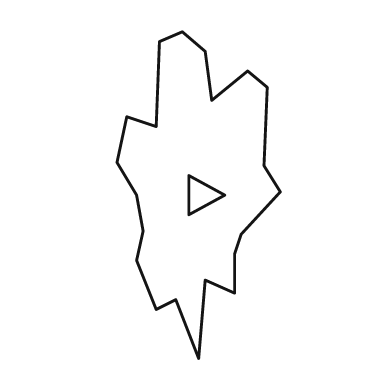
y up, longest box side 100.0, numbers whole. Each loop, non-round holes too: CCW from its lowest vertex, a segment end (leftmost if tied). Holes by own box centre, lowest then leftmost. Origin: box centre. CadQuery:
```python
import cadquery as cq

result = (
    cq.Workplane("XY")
    .moveTo(0.0, -50.0)
    .lineTo(2.0, -26.0)
    .lineTo(11.0, -30.0)
    .lineTo(11.0, -18.0)
    .lineTo(13.0, -12.0)
    .lineTo(25.0, 1.0)
    .lineTo(20.0, 9.0)
    .lineTo(21.0, 33.0)
    .lineTo(15.0, 38.0)
    .lineTo(4.0, 29.0)
    .lineTo(2.0, 44.0)
    .lineTo(-5.0, 50.0)
    .lineTo(-12.0, 47.0)
    .lineTo(-13.0, 21.0)
    .lineTo(-22.0, 24.0)
    .lineTo(-25.0, 10.0)
    .lineTo(-19.0, 0.0)
    .lineTo(-17.0, -11.0)
    .lineTo(-19.0, -20.0)
    .lineTo(-13.0, -35.0)
    .lineTo(-7.0, -32.0)
    .close()
    .moveTo(-3.0, -6.0)
    .lineTo(8.0, 0.0)
    .lineTo(-3.0, 6.0)
    .close()
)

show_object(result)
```